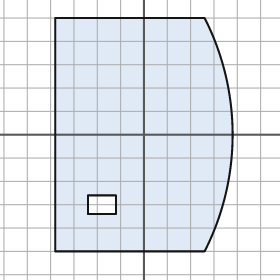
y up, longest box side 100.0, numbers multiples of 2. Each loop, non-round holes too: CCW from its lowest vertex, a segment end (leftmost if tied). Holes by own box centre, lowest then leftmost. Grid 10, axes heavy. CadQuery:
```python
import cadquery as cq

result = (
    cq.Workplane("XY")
    .moveTo(-38.0, -50.0)
    .lineTo(26.0, -50.0)
    .threePointArc((38.0, 0.0), (26.0, 50.0))
    .lineTo(-38.0, 50.0)
    .close()
    .moveTo(-24.0, -34.0)
    .lineTo(-12.0, -34.0)
    .lineTo(-12.0, -26.0)
    .lineTo(-24.0, -26.0)
    .close()
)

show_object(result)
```